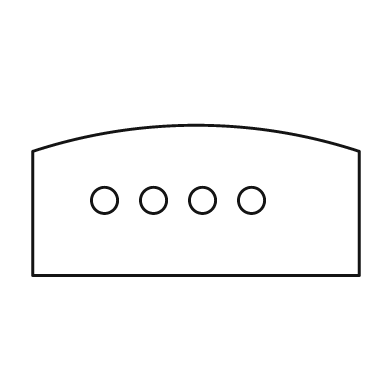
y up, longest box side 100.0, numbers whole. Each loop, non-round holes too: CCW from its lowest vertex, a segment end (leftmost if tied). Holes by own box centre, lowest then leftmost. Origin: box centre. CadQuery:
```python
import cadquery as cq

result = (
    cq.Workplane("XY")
    .moveTo(-50.0, -23.0)
    .lineTo(50.0, -23.0)
    .lineTo(50.0, 15.0)
    .threePointArc((0.0, 23.0), (-50.0, 15.0))
    .close()
    .moveTo(-28.0, 0.0)
    .circle(4.0)
    .moveTo(-13.0, 0.0)
    .circle(4.0)
    .moveTo(2.0, 0.0)
    .circle(4.0)
    .moveTo(17.0, 0.0)
    .circle(4.0)
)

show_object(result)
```